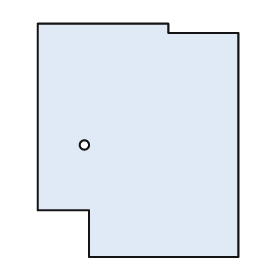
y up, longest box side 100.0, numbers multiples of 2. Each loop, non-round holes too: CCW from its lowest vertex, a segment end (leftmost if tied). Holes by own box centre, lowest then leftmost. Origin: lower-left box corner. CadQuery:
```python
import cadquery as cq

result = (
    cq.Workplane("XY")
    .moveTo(22.0, 0.0)
    .lineTo(86.0, 0.0)
    .lineTo(86.0, 96.0)
    .lineTo(56.0, 96.0)
    .lineTo(56.0, 100.0)
    .lineTo(0.0, 100.0)
    .lineTo(0.0, 20.0)
    .lineTo(22.0, 20.0)
    .close()
    .moveTo(20.0, 48.0)
    .circle(2.0)
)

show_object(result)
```